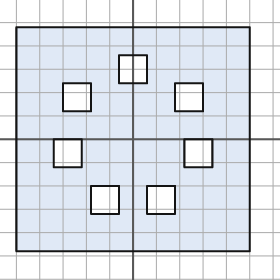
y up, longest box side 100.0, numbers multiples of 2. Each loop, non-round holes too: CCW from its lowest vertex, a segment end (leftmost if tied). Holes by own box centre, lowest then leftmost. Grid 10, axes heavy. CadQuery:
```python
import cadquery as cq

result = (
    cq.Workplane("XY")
    .moveTo(-50.0, -48.0)
    .lineTo(50.0, -48.0)
    .lineTo(50.0, 48.0)
    .lineTo(-50.0, 48.0)
    .close()
    .moveTo(-18.0, -32.0)
    .lineTo(-6.0, -32.0)
    .lineTo(-6.0, -20.0)
    .lineTo(-18.0, -20.0)
    .close()
    .moveTo(6.0, -32.0)
    .lineTo(18.0, -32.0)
    .lineTo(18.0, -20.0)
    .lineTo(6.0, -20.0)
    .close()
    .moveTo(-34.0, -12.0)
    .lineTo(-22.0, -12.0)
    .lineTo(-22.0, 0.0)
    .lineTo(-34.0, 0.0)
    .close()
    .moveTo(22.0, -12.0)
    .lineTo(34.0, -12.0)
    .lineTo(34.0, 0.0)
    .lineTo(22.0, 0.0)
    .close()
    .moveTo(-30.0, 12.0)
    .lineTo(-18.0, 12.0)
    .lineTo(-18.0, 24.0)
    .lineTo(-30.0, 24.0)
    .close()
    .moveTo(18.0, 12.0)
    .lineTo(30.0, 12.0)
    .lineTo(30.0, 24.0)
    .lineTo(18.0, 24.0)
    .close()
    .moveTo(-6.0, 24.0)
    .lineTo(6.0, 24.0)
    .lineTo(6.0, 36.0)
    .lineTo(-6.0, 36.0)
    .close()
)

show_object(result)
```